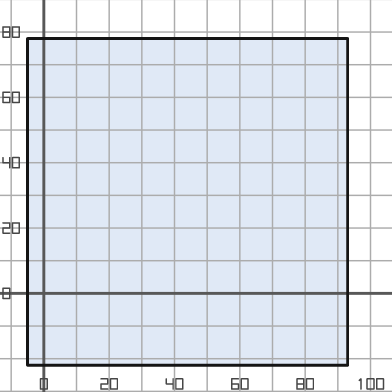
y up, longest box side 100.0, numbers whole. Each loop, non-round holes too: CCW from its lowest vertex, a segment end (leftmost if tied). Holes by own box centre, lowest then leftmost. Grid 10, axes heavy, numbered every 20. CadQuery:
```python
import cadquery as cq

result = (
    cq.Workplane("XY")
    .moveTo(-5.0, -22.0)
    .lineTo(93.0, -22.0)
    .lineTo(93.0, 78.0)
    .lineTo(-5.0, 78.0)
    .close()
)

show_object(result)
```